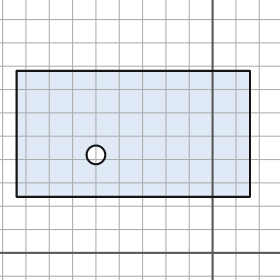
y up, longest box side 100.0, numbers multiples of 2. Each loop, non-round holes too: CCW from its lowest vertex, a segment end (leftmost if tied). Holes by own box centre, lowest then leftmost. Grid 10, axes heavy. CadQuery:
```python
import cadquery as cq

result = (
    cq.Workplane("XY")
    .moveTo(-84.0, 24.0)
    .lineTo(16.0, 24.0)
    .lineTo(16.0, 78.0)
    .lineTo(-84.0, 78.0)
    .close()
    .moveTo(-50.0, 42.0)
    .circle(4.0)
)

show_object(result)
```